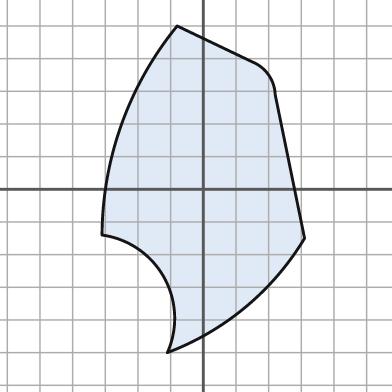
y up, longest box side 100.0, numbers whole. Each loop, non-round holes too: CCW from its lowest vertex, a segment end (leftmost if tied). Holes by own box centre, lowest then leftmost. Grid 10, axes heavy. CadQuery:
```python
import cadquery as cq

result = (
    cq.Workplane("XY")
    .moveTo(-11.0, -50.0)
    .threePointArc((13.0, -36.0), (31.0, -15.0))
    .lineTo(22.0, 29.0)
    .threePointArc((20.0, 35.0), (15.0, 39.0))
    .lineTo(-8.0, 50.0)
    .threePointArc((-25.0, 20.0), (-31.0, -14.0))
    .threePointArc((-12.0, -27.0), (-11.0, -50.0))
    .close()
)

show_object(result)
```